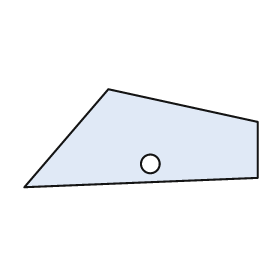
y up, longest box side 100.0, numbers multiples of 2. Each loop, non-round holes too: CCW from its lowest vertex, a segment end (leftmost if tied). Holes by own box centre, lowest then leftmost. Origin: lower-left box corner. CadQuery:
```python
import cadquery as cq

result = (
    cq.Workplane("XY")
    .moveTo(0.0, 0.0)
    .lineTo(100.0, 4.0)
    .lineTo(100.0, 28.0)
    .lineTo(36.0, 42.0)
    .close()
    .moveTo(54.0, 10.0)
    .circle(4.0)
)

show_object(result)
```